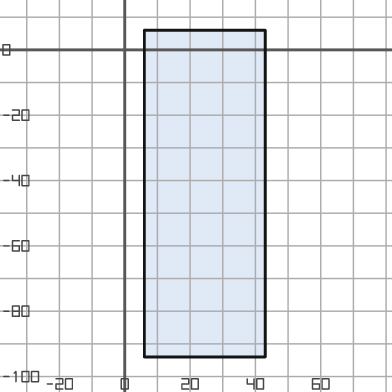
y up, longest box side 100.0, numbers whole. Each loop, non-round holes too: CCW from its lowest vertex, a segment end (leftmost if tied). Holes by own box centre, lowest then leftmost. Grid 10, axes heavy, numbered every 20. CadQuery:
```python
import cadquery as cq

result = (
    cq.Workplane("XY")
    .moveTo(6.0, -94.0)
    .lineTo(43.0, -94.0)
    .lineTo(43.0, 6.0)
    .lineTo(6.0, 6.0)
    .close()
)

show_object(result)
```